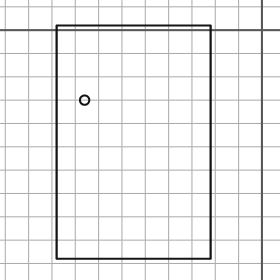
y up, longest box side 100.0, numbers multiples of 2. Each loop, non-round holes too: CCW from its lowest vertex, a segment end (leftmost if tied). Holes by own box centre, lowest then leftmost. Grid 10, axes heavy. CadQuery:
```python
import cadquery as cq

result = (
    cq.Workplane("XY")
    .moveTo(-88.0, -98.0)
    .lineTo(-22.0, -98.0)
    .lineTo(-22.0, 2.0)
    .lineTo(-88.0, 2.0)
    .close()
    .moveTo(-76.0, -30.0)
    .circle(2.0)
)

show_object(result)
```